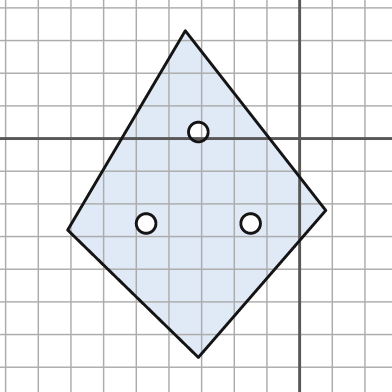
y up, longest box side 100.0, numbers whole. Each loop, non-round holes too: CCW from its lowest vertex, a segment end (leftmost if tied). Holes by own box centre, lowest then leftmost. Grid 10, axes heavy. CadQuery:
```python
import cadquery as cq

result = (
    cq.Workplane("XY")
    .moveTo(-31.0, -67.0)
    .lineTo(8.0, -22.0)
    .lineTo(-35.0, 33.0)
    .lineTo(-71.0, -28.0)
    .close()
    .moveTo(-47.0, -26.0)
    .circle(3.0)
    .moveTo(-15.0, -26.0)
    .circle(3.0)
    .moveTo(-31.0, 2.0)
    .circle(3.0)
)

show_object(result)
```